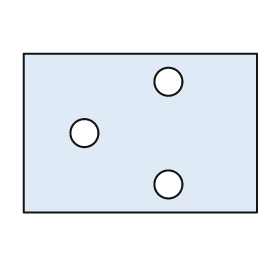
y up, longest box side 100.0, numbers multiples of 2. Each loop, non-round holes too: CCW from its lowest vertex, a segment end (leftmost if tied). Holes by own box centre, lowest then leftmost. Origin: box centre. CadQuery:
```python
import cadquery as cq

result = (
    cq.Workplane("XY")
    .moveTo(-50.0, -34.0)
    .lineTo(50.0, -34.0)
    .lineTo(50.0, 34.0)
    .lineTo(-50.0, 34.0)
    .close()
    .moveTo(12.0, -22.0)
    .circle(6.0)
    .moveTo(-24.0, 0.0)
    .circle(6.0)
    .moveTo(12.0, 22.0)
    .circle(6.0)
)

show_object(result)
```